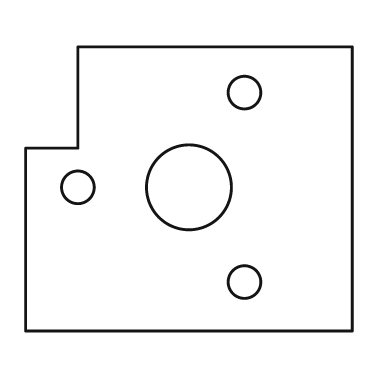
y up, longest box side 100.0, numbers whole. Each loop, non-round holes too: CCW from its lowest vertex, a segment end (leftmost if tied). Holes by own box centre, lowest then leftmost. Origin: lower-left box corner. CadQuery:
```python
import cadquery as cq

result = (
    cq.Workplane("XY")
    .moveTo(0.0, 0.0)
    .lineTo(100.0, 0.0)
    .lineTo(100.0, 87.0)
    .lineTo(16.0, 87.0)
    .lineTo(16.0, 56.0)
    .lineTo(0.0, 56.0)
    .close()
    .moveTo(67.0, 15.0)
    .circle(5.0)
    .moveTo(16.0, 44.0)
    .circle(5.0)
    .moveTo(50.0, 44.0)
    .circle(13.0)
    .moveTo(67.0, 73.0)
    .circle(5.0)
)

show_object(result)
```